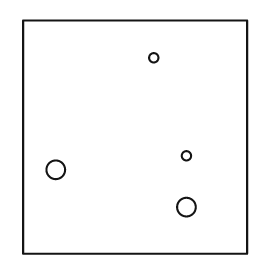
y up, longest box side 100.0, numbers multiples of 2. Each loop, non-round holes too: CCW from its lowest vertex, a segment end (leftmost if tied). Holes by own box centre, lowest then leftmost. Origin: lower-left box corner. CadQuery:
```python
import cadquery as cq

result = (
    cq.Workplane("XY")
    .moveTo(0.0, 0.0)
    .lineTo(96.0, 0.0)
    .lineTo(96.0, 100.0)
    .lineTo(0.0, 100.0)
    .close()
    .moveTo(70.0, 20.0)
    .circle(4.0)
    .moveTo(14.0, 36.0)
    .circle(4.0)
    .moveTo(70.0, 42.0)
    .circle(2.0)
    .moveTo(56.0, 84.0)
    .circle(2.0)
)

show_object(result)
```